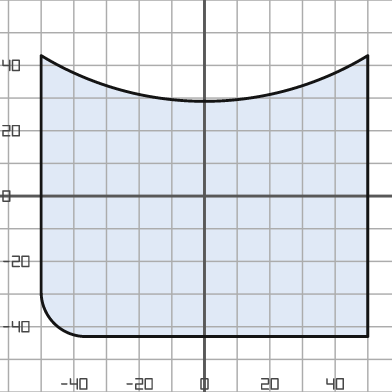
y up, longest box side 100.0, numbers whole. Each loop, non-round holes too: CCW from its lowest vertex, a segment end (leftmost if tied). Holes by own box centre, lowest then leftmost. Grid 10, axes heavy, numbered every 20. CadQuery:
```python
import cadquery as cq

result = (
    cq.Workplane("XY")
    .moveTo(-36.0, -43.0)
    .lineTo(50.0, -43.0)
    .lineTo(50.0, 43.0)
    .threePointArc((0.0, 29.0), (-50.0, 43.0))
    .lineTo(-50.0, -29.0)
    .threePointArc((-46.0, -39.0), (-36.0, -43.0))
    .close()
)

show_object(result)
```